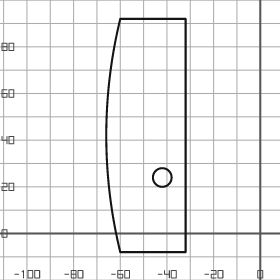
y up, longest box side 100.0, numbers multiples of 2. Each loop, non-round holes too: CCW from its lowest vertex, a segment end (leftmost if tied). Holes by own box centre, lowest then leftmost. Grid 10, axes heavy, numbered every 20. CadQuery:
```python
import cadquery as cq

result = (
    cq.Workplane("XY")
    .moveTo(-60.0, -8.0)
    .lineTo(-32.0, -8.0)
    .lineTo(-32.0, 92.0)
    .lineTo(-60.0, 92.0)
    .threePointArc((-66.0, 42.0), (-60.0, -8.0))
    .close()
    .moveTo(-42.0, 24.0)
    .circle(4.0)
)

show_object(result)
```